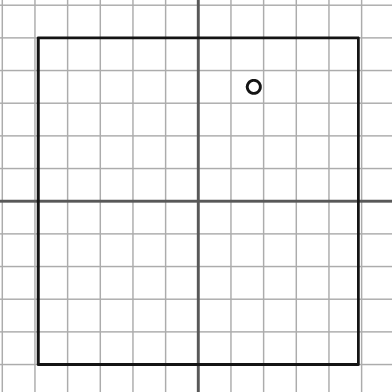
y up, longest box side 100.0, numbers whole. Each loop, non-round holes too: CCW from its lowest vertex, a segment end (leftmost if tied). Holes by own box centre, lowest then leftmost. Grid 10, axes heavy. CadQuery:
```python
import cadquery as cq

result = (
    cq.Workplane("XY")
    .moveTo(-49.0, -50.0)
    .lineTo(49.0, -50.0)
    .lineTo(49.0, 50.0)
    .lineTo(-49.0, 50.0)
    .close()
    .moveTo(17.0, 35.0)
    .circle(2.0)
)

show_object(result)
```